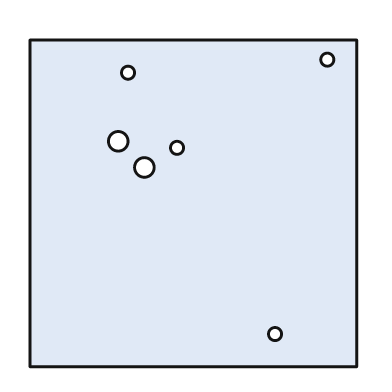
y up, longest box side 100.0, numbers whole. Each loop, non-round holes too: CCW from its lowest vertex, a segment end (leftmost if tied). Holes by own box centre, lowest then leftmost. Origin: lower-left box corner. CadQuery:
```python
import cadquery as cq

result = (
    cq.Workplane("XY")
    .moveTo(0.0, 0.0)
    .lineTo(100.0, 0.0)
    .lineTo(100.0, 100.0)
    .lineTo(0.0, 100.0)
    .close()
    .moveTo(75.0, 10.0)
    .circle(2.0)
    .moveTo(35.0, 61.0)
    .circle(3.0)
    .moveTo(45.0, 67.0)
    .circle(2.0)
    .moveTo(27.0, 69.0)
    .circle(3.0)
    .moveTo(30.0, 90.0)
    .circle(2.0)
    .moveTo(91.0, 94.0)
    .circle(2.0)
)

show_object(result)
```